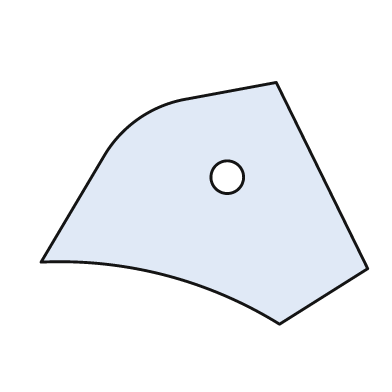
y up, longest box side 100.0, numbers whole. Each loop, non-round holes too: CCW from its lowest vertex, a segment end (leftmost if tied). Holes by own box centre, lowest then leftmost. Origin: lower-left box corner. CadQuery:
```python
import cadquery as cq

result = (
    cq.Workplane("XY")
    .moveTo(73.0, 0.0)
    .lineTo(100.0, 17.0)
    .lineTo(72.0, 74.0)
    .lineTo(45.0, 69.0)
    .threePointArc((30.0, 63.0), (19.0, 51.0))
    .lineTo(0.0, 19.0)
    .threePointArc((38.0, 15.0), (73.0, 0.0))
    .close()
    .moveTo(57.0, 45.0)
    .circle(5.0)
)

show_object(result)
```